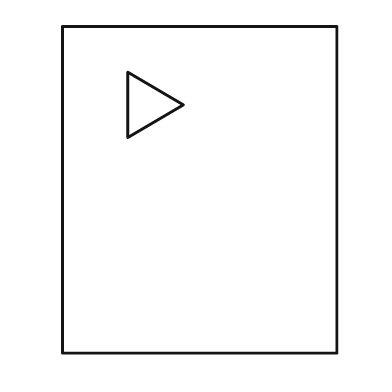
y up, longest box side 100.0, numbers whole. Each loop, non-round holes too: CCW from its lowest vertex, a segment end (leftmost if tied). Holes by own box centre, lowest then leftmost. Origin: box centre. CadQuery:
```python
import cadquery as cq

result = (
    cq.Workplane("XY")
    .moveTo(-42.0, -50.0)
    .lineTo(42.0, -50.0)
    .lineTo(42.0, 50.0)
    .lineTo(-42.0, 50.0)
    .close()
    .moveTo(-22.0, 16.0)
    .lineTo(-5.0, 26.0)
    .lineTo(-22.0, 36.0)
    .close()
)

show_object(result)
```